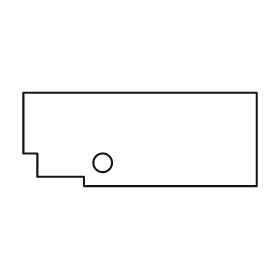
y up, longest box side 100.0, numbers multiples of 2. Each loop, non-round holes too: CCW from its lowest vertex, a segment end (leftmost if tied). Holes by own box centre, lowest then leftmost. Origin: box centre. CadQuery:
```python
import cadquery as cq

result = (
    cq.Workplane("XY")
    .moveTo(-24.0, -20.0)
    .lineTo(50.0, -20.0)
    .lineTo(50.0, 20.0)
    .lineTo(-50.0, 20.0)
    .lineTo(-50.0, -6.0)
    .lineTo(-44.0, -6.0)
    .lineTo(-44.0, -16.0)
    .lineTo(-24.0, -16.0)
    .close()
    .moveTo(-16.0, -10.0)
    .circle(4.0)
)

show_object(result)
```